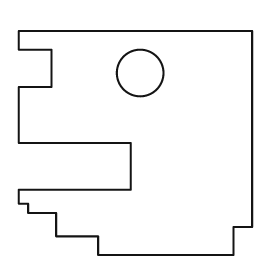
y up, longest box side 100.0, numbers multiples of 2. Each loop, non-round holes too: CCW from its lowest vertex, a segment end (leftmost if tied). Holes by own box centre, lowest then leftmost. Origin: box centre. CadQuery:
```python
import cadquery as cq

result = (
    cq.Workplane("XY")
    .moveTo(-16.0, -48.0)
    .lineTo(42.0, -48.0)
    .lineTo(42.0, -36.0)
    .lineTo(50.0, -36.0)
    .lineTo(50.0, 48.0)
    .lineTo(-50.0, 48.0)
    .lineTo(-50.0, 40.0)
    .lineTo(-36.0, 40.0)
    .lineTo(-36.0, 24.0)
    .lineTo(-50.0, 24.0)
    .lineTo(-50.0, 0.0)
    .lineTo(-2.0, 0.0)
    .lineTo(-2.0, -20.0)
    .lineTo(-50.0, -20.0)
    .lineTo(-50.0, -26.0)
    .lineTo(-46.0, -26.0)
    .lineTo(-46.0, -30.0)
    .lineTo(-34.0, -30.0)
    .lineTo(-34.0, -40.0)
    .lineTo(-16.0, -40.0)
    .close()
    .moveTo(2.0, 30.0)
    .circle(10.0)
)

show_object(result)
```